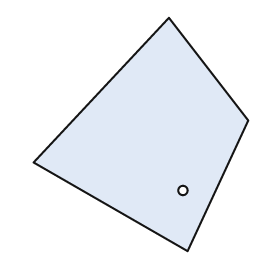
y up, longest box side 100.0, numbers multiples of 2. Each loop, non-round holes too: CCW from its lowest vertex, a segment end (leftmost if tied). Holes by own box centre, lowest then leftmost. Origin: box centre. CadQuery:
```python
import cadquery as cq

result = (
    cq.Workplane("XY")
    .moveTo(20.0, -50.0)
    .lineTo(46.0, 6.0)
    .lineTo(12.0, 50.0)
    .lineTo(-46.0, -12.0)
    .close()
    .moveTo(18.0, -24.0)
    .circle(2.0)
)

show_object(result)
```